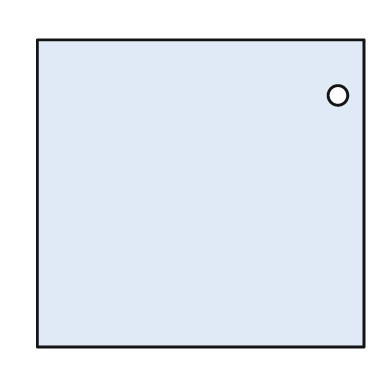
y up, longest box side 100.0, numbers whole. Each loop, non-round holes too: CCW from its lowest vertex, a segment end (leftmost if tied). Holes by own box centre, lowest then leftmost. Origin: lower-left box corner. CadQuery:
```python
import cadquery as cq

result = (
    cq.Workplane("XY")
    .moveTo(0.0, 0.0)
    .lineTo(100.0, 0.0)
    .lineTo(100.0, 94.0)
    .lineTo(0.0, 94.0)
    .close()
    .moveTo(92.0, 77.0)
    .circle(3.0)
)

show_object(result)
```